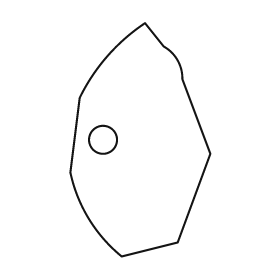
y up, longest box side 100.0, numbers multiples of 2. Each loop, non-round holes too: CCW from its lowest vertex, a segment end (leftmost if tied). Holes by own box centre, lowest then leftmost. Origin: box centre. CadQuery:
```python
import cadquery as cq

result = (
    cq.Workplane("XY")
    .moveTo(-8.0, -50.0)
    .lineTo(16.0, -44.0)
    .lineTo(30.0, -6.0)
    .lineTo(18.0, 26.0)
    .threePointArc((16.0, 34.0), (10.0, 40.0))
    .lineTo(2.0, 50.0)
    .threePointArc((-14.0, 36.0), (-26.0, 18.0))
    .lineTo(-30.0, -14.0)
    .threePointArc((-22.0, -34.0), (-8.0, -50.0))
    .close()
    .moveTo(-16.0, 0.0)
    .circle(6.0)
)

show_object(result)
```